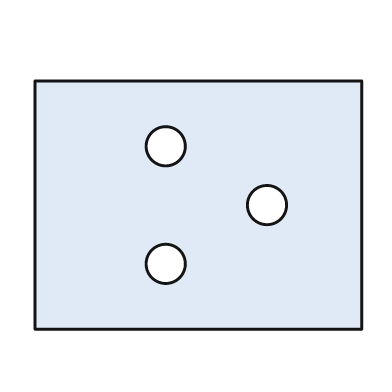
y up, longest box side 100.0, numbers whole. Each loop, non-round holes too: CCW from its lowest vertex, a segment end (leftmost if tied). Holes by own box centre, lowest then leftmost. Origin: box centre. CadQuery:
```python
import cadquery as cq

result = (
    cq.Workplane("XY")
    .moveTo(-50.0, -38.0)
    .lineTo(50.0, -38.0)
    .lineTo(50.0, 38.0)
    .lineTo(-50.0, 38.0)
    .close()
    .moveTo(-10.0, -18.0)
    .circle(6.0)
    .moveTo(21.0, 0.0)
    .circle(6.0)
    .moveTo(-10.0, 18.0)
    .circle(6.0)
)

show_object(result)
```